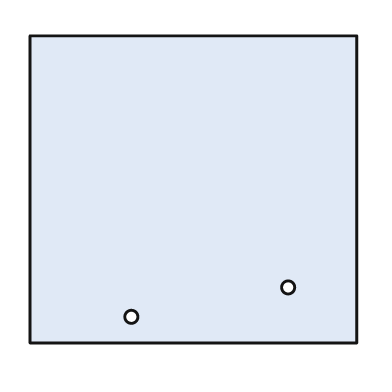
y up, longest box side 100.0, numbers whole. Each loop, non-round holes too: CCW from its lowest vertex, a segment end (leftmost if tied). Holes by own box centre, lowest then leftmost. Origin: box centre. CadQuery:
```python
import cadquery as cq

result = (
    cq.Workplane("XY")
    .moveTo(-50.0, -47.0)
    .lineTo(50.0, -47.0)
    .lineTo(50.0, 47.0)
    .lineTo(-50.0, 47.0)
    .close()
    .moveTo(-19.0, -39.0)
    .circle(2.0)
    .moveTo(29.0, -30.0)
    .circle(2.0)
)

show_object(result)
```